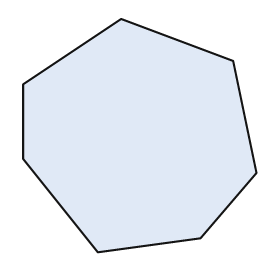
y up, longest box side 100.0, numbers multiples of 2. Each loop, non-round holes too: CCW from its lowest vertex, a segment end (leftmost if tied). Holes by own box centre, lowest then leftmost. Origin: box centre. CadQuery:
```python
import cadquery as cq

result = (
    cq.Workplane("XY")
    .moveTo(-18.0, -50.0)
    .lineTo(26.0, -44.0)
    .lineTo(50.0, -16.0)
    .lineTo(40.0, 32.0)
    .lineTo(-8.0, 50.0)
    .lineTo(-50.0, 22.0)
    .lineTo(-50.0, -10.0)
    .close()
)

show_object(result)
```